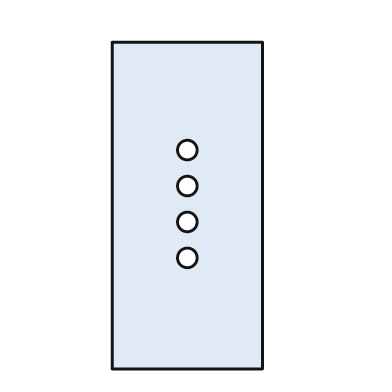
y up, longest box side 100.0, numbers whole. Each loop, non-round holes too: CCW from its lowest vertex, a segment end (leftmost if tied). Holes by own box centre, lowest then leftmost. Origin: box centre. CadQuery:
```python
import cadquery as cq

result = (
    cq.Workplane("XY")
    .moveTo(-23.0, -50.0)
    .lineTo(23.0, -50.0)
    .lineTo(23.0, 50.0)
    .lineTo(-23.0, 50.0)
    .close()
    .moveTo(0.0, -16.0)
    .circle(3.0)
    .moveTo(0.0, -5.0)
    .circle(3.0)
    .moveTo(0.0, 6.0)
    .circle(3.0)
    .moveTo(0.0, 17.0)
    .circle(3.0)
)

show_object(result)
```